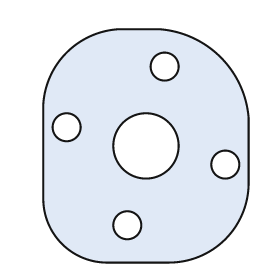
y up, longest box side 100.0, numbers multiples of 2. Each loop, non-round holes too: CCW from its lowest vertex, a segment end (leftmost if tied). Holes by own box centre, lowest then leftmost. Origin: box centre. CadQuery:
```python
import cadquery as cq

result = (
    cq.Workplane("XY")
    .moveTo(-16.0, -50.0)
    .lineTo(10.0, -50.0)
    .threePointArc((34.0, -40.0), (44.0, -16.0))
    .lineTo(44.0, 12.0)
    .threePointArc((32.0, 38.0), (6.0, 50.0))
    .lineTo(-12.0, 50.0)
    .threePointArc((-34.0, 40.0), (-44.0, 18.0))
    .lineTo(-44.0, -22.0)
    .threePointArc((-36.0, -42.0), (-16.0, -50.0))
    .close()
    .moveTo(-8.0, -34.0)
    .circle(6.0)
    .moveTo(34.0, -8.0)
    .circle(6.0)
    .moveTo(0.0, 0.0)
    .circle(14.0)
    .moveTo(-34.0, 8.0)
    .circle(6.0)
    .moveTo(8.0, 34.0)
    .circle(6.0)
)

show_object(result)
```